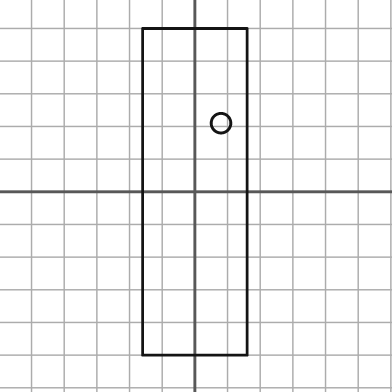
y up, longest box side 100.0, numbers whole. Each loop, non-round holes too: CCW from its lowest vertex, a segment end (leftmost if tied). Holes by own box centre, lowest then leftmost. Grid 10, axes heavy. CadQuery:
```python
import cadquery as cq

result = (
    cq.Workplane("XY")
    .moveTo(-16.0, -50.0)
    .lineTo(16.0, -50.0)
    .lineTo(16.0, 50.0)
    .lineTo(-16.0, 50.0)
    .close()
    .moveTo(8.0, 21.0)
    .circle(3.0)
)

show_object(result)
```